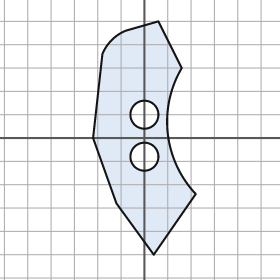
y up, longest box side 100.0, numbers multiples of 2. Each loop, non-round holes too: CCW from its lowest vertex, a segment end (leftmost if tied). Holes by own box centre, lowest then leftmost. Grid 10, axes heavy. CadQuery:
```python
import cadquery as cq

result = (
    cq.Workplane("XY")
    .moveTo(4.0, -50.0)
    .lineTo(22.0, -24.0)
    .threePointArc((10.0, 2.0), (16.0, 30.0))
    .lineTo(6.0, 50.0)
    .lineTo(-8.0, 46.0)
    .threePointArc((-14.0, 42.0), (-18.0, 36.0))
    .lineTo(-22.0, 0.0)
    .lineTo(-12.0, -28.0)
    .close()
    .moveTo(0.0, -8.0)
    .circle(6.0)
    .moveTo(0.0, 10.0)
    .circle(6.0)
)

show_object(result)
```